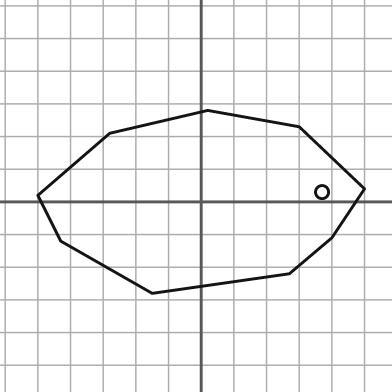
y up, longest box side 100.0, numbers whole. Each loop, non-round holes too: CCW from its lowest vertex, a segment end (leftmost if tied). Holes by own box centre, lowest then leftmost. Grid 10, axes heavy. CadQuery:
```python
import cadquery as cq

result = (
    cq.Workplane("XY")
    .moveTo(-15.0, -28.0)
    .lineTo(27.0, -22.0)
    .lineTo(40.0, -11.0)
    .lineTo(50.0, 4.0)
    .lineTo(30.0, 23.0)
    .lineTo(2.0, 28.0)
    .lineTo(-28.0, 21.0)
    .lineTo(-50.0, 2.0)
    .lineTo(-43.0, -12.0)
    .close()
    .moveTo(37.0, 3.0)
    .circle(2.0)
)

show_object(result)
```